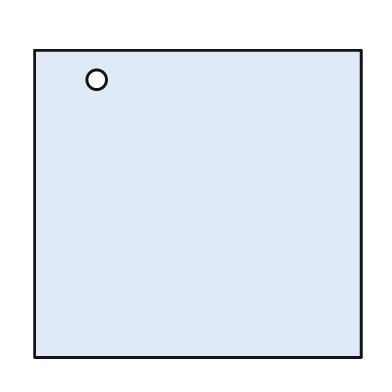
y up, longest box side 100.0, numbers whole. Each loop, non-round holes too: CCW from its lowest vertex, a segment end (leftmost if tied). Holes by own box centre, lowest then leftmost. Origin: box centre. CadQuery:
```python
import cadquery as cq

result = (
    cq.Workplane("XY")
    .moveTo(-50.0, -47.0)
    .lineTo(50.0, -47.0)
    .lineTo(50.0, 47.0)
    .lineTo(-50.0, 47.0)
    .close()
    .moveTo(-31.0, 38.0)
    .circle(3.0)
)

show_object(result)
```